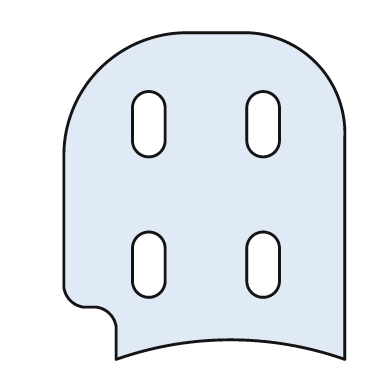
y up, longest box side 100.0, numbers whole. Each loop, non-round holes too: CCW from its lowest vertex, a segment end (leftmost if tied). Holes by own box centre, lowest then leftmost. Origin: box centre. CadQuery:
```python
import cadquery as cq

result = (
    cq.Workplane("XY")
    .moveTo(-27.0, -50.0)
    .threePointArc((8.0, -44.0), (43.0, -50.0))
    .lineTo(43.0, 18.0)
    .threePointArc((34.0, 41.0), (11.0, 50.0))
    .lineTo(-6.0, 50.0)
    .threePointArc((-32.0, 39.0), (-43.0, 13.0))
    .lineTo(-43.0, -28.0)
    .threePointArc((-41.0, -32.0), (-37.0, -34.0))
    .lineTo(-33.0, -34.0)
    .threePointArc((-29.0, -36.0), (-27.0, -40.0))
    .close()
    .moveTo(-22.0, -26.0)
    .threePointArc((-17.0, -31.0), (-12.0, -26.0))
    .lineTo(-12.0, -16.0)
    .threePointArc((-17.0, -11.0), (-22.0, -16.0))
    .close()
    .moveTo(13.0, -26.0)
    .threePointArc((18.0, -31.0), (23.0, -26.0))
    .lineTo(23.0, -16.0)
    .threePointArc((18.0, -11.0), (13.0, -16.0))
    .close()
    .moveTo(-22.0, 17.0)
    .threePointArc((-17.0, 12.0), (-12.0, 17.0))
    .lineTo(-12.0, 27.0)
    .threePointArc((-17.0, 32.0), (-22.0, 27.0))
    .close()
    .moveTo(13.0, 17.0)
    .threePointArc((18.0, 12.0), (23.0, 17.0))
    .lineTo(23.0, 27.0)
    .threePointArc((18.0, 32.0), (13.0, 27.0))
    .close()
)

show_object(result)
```